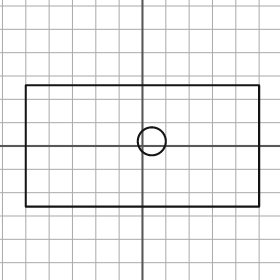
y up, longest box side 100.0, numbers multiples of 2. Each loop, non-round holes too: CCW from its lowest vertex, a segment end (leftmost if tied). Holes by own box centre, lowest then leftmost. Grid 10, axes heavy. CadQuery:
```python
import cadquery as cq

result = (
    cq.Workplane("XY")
    .moveTo(-50.0, -26.0)
    .lineTo(50.0, -26.0)
    .lineTo(50.0, 26.0)
    .lineTo(-50.0, 26.0)
    .close()
    .moveTo(4.0, 2.0)
    .circle(6.0)
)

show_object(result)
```